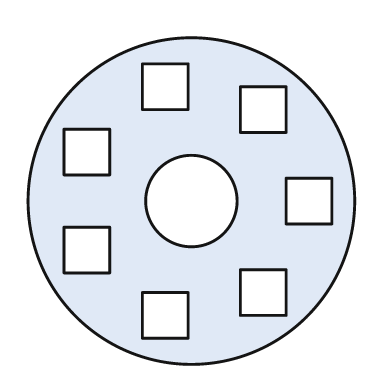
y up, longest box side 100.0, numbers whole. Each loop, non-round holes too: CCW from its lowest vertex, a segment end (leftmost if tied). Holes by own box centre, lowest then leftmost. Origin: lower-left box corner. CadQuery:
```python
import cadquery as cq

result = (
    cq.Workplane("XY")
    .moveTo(50.0, 50.0)
    .circle(50.0)
    .moveTo(35.0, 8.0)
    .lineTo(49.0, 8.0)
    .lineTo(49.0, 22.0)
    .lineTo(35.0, 22.0)
    .close()
    .moveTo(65.0, 15.0)
    .lineTo(79.0, 15.0)
    .lineTo(79.0, 29.0)
    .lineTo(65.0, 29.0)
    .close()
    .moveTo(11.0, 28.0)
    .lineTo(25.0, 28.0)
    .lineTo(25.0, 42.0)
    .lineTo(11.0, 42.0)
    .close()
    .moveTo(50.0, 50.0)
    .circle(14.0)
    .moveTo(79.0, 43.0)
    .lineTo(93.0, 43.0)
    .lineTo(93.0, 57.0)
    .lineTo(79.0, 57.0)
    .close()
    .moveTo(11.0, 58.0)
    .lineTo(25.0, 58.0)
    .lineTo(25.0, 72.0)
    .lineTo(11.0, 72.0)
    .close()
    .moveTo(65.0, 71.0)
    .lineTo(79.0, 71.0)
    .lineTo(79.0, 85.0)
    .lineTo(65.0, 85.0)
    .close()
    .moveTo(35.0, 78.0)
    .lineTo(49.0, 78.0)
    .lineTo(49.0, 92.0)
    .lineTo(35.0, 92.0)
    .close()
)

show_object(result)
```